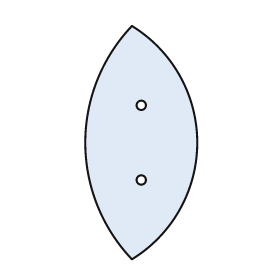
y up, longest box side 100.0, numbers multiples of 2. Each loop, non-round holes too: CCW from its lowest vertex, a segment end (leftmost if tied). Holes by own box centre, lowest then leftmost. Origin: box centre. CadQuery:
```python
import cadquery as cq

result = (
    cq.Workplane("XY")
    .moveTo(-4.0, -50.0)
    .threePointArc((24.0, 0.0), (-4.0, 50.0))
    .threePointArc((-24.0, 0.0), (-4.0, -50.0))
    .close()
    .moveTo(0.0, -16.0)
    .circle(2.0)
    .moveTo(0.0, 16.0)
    .circle(2.0)
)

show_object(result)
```